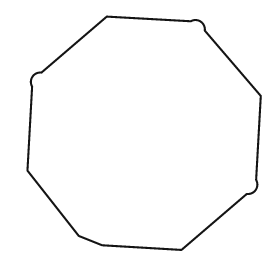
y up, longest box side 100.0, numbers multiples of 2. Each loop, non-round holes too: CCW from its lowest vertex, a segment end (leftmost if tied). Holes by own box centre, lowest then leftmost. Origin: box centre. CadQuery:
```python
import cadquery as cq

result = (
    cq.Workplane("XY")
    .moveTo(16.0, -50.0)
    .lineTo(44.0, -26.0)
    .threePointArc((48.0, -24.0), (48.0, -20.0))
    .lineTo(50.0, 16.0)
    .lineTo(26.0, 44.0)
    .threePointArc((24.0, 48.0), (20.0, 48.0))
    .lineTo(-16.0, 50.0)
    .lineTo(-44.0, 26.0)
    .threePointArc((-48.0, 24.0), (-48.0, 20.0))
    .lineTo(-50.0, -16.0)
    .lineTo(-28.0, -44.0)
    .lineTo(-18.0, -48.0)
    .close()
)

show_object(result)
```